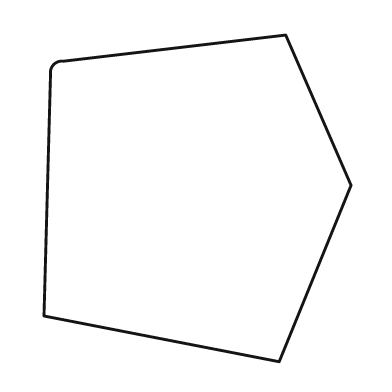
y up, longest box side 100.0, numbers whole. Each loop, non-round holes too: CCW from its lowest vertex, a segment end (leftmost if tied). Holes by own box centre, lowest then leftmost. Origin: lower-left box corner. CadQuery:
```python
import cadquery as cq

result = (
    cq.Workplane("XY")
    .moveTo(72.0, 0.0)
    .lineTo(94.0, 54.0)
    .lineTo(74.0, 100.0)
    .lineTo(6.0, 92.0)
    .threePointArc((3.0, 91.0), (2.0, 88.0))
    .lineTo(0.0, 14.0)
    .close()
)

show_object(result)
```